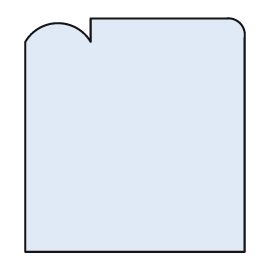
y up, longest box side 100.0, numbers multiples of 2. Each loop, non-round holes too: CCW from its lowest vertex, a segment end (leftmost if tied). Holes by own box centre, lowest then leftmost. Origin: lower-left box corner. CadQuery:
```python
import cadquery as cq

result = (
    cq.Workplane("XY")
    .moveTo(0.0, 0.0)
    .lineTo(94.0, 0.0)
    .lineTo(94.0, 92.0)
    .threePointArc((92.0, 98.0), (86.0, 100.0))
    .lineTo(28.0, 100.0)
    .lineTo(28.0, 90.0)
    .threePointArc((14.0, 98.0), (0.0, 90.0))
    .close()
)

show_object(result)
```